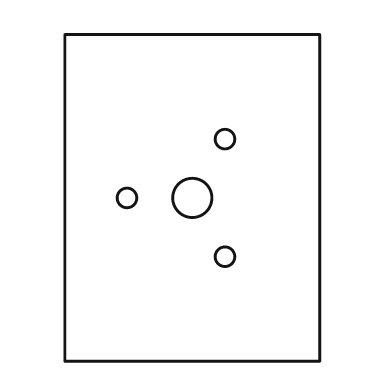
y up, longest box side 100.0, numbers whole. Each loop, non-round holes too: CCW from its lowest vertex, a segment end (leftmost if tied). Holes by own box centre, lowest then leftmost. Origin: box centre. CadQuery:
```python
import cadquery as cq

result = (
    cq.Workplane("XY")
    .moveTo(-39.0, -50.0)
    .lineTo(39.0, -50.0)
    .lineTo(39.0, 50.0)
    .lineTo(-39.0, 50.0)
    .close()
    .moveTo(10.0, -18.0)
    .circle(3.0)
    .moveTo(-20.0, 0.0)
    .circle(3.0)
    .moveTo(0.0, 0.0)
    .circle(6.0)
    .moveTo(10.0, 18.0)
    .circle(3.0)
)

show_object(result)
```